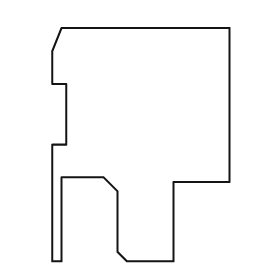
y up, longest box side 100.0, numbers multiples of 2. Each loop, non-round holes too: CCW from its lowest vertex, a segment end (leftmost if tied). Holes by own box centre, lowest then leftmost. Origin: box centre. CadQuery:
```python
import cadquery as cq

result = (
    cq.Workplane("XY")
    .moveTo(-38.0, -50.0)
    .lineTo(-34.0, -50.0)
    .lineTo(-34.0, -14.0)
    .lineTo(-16.0, -14.0)
    .lineTo(-10.0, -20.0)
    .lineTo(-10.0, -46.0)
    .lineTo(-6.0, -50.0)
    .lineTo(14.0, -50.0)
    .lineTo(14.0, -16.0)
    .lineTo(38.0, -16.0)
    .lineTo(38.0, 50.0)
    .lineTo(-34.0, 50.0)
    .lineTo(-38.0, 40.0)
    .lineTo(-38.0, 26.0)
    .lineTo(-32.0, 26.0)
    .lineTo(-32.0, 0.0)
    .lineTo(-38.0, 0.0)
    .close()
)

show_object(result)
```